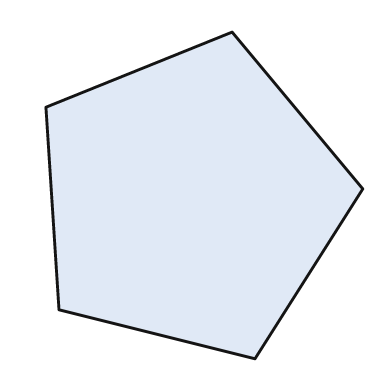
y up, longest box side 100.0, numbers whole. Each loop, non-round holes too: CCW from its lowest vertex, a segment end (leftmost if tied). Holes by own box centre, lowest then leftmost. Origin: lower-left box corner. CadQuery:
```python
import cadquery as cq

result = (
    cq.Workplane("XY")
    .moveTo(64.0, 0.0)
    .lineTo(97.0, 52.0)
    .lineTo(57.0, 100.0)
    .lineTo(0.0, 77.0)
    .lineTo(4.0, 15.0)
    .close()
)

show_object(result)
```